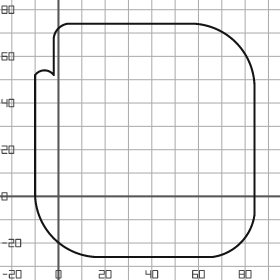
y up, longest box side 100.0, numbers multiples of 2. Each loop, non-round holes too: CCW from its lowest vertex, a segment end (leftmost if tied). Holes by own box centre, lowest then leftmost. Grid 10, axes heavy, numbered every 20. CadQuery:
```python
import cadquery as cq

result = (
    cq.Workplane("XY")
    .moveTo(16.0, -26.0)
    .lineTo(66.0, -26.0)
    .threePointArc((78.0, -20.0), (84.0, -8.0))
    .lineTo(84.0, 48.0)
    .threePointArc((76.0, 66.0), (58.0, 74.0))
    .lineTo(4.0, 74.0)
    .threePointArc((0.0, 72.0), (-2.0, 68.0))
    .lineTo(-2.0, 52.0)
    .threePointArc((-6.0, 54.0), (-10.0, 52.0))
    .lineTo(-10.0, 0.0)
    .threePointArc((-2.0, -18.0), (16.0, -26.0))
    .close()
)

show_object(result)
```